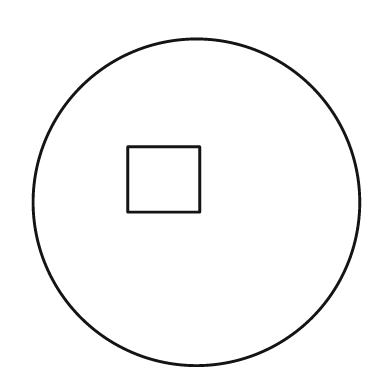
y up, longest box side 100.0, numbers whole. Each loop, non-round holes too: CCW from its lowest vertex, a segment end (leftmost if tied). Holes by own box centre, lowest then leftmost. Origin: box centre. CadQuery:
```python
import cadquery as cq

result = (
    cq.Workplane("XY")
    .moveTo(0.0, 0.0)
    .circle(50.0)
    .moveTo(-21.0, -3.0)
    .lineTo(1.0, -3.0)
    .lineTo(1.0, 17.0)
    .lineTo(-21.0, 17.0)
    .close()
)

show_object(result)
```